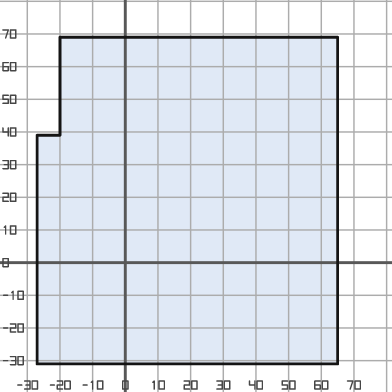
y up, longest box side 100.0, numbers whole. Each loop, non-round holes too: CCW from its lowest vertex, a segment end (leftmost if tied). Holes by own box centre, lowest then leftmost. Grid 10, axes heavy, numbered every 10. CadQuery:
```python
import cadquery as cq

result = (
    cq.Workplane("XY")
    .moveTo(-27.0, -31.0)
    .lineTo(65.0, -31.0)
    .lineTo(65.0, 69.0)
    .lineTo(-20.0, 69.0)
    .lineTo(-20.0, 39.0)
    .lineTo(-27.0, 39.0)
    .close()
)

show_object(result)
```